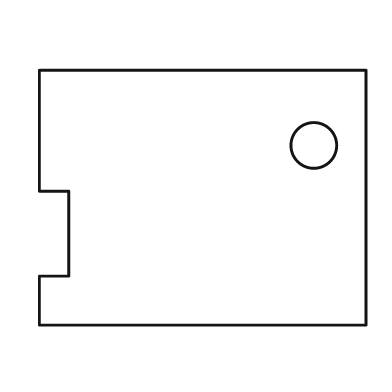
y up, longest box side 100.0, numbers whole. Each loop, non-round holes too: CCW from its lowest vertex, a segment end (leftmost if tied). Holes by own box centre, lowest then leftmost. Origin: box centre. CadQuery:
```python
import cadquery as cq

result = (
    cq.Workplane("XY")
    .moveTo(-50.0, -39.0)
    .lineTo(50.0, -39.0)
    .lineTo(50.0, 39.0)
    .lineTo(-50.0, 39.0)
    .lineTo(-50.0, 2.0)
    .lineTo(-41.0, 2.0)
    .lineTo(-41.0, -24.0)
    .lineTo(-50.0, -24.0)
    .close()
    .moveTo(34.0, 16.0)
    .circle(7.0)
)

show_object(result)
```